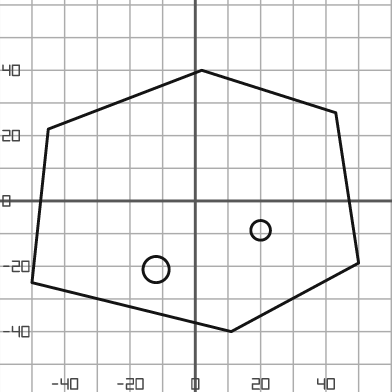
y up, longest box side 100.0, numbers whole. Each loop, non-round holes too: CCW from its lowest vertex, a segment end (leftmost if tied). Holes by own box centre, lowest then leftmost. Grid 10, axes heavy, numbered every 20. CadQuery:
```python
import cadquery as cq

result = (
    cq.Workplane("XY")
    .moveTo(11.0, -40.0)
    .lineTo(50.0, -19.0)
    .lineTo(43.0, 27.0)
    .lineTo(2.0, 40.0)
    .lineTo(-45.0, 22.0)
    .lineTo(-50.0, -25.0)
    .close()
    .moveTo(-12.0, -21.0)
    .circle(4.0)
    .moveTo(20.0, -9.0)
    .circle(3.0)
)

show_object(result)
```